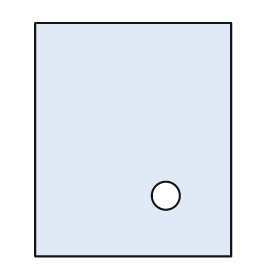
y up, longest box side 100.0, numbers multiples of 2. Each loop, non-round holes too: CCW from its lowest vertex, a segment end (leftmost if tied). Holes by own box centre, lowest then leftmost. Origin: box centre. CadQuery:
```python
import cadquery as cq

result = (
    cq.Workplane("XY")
    .moveTo(-42.0, -50.0)
    .lineTo(42.0, -50.0)
    .lineTo(42.0, 50.0)
    .lineTo(-42.0, 50.0)
    .close()
    .moveTo(14.0, -24.0)
    .circle(6.0)
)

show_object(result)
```